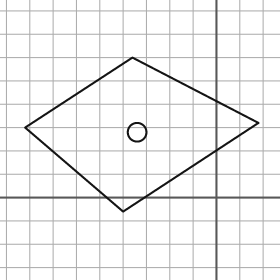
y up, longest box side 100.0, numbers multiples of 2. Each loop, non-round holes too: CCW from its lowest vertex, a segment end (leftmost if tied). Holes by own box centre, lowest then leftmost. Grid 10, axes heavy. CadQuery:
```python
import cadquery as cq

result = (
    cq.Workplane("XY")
    .moveTo(-40.0, -6.0)
    .lineTo(18.0, 32.0)
    .lineTo(-36.0, 60.0)
    .lineTo(-82.0, 30.0)
    .close()
    .moveTo(-34.0, 28.0)
    .circle(4.0)
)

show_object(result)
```